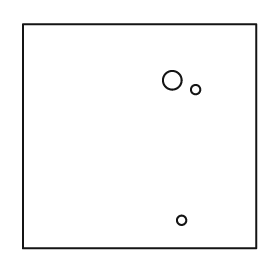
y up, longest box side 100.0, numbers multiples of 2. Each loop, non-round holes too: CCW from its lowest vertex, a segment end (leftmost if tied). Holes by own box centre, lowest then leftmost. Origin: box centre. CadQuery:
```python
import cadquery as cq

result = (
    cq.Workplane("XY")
    .moveTo(-50.0, -48.0)
    .lineTo(50.0, -48.0)
    .lineTo(50.0, 48.0)
    .lineTo(-50.0, 48.0)
    .close()
    .moveTo(18.0, -36.0)
    .circle(2.0)
    .moveTo(24.0, 20.0)
    .circle(2.0)
    .moveTo(14.0, 24.0)
    .circle(4.0)
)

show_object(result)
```